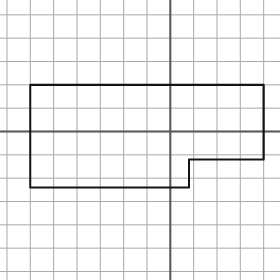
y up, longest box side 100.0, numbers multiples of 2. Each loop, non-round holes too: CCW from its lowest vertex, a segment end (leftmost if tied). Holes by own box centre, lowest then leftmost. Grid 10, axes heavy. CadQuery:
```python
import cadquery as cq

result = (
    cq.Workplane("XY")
    .moveTo(-60.0, -24.0)
    .lineTo(8.0, -24.0)
    .lineTo(8.0, -12.0)
    .lineTo(40.0, -12.0)
    .lineTo(40.0, 20.0)
    .lineTo(-60.0, 20.0)
    .close()
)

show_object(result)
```